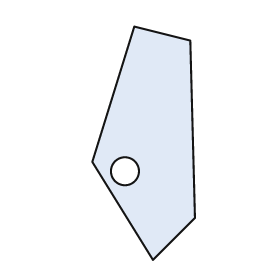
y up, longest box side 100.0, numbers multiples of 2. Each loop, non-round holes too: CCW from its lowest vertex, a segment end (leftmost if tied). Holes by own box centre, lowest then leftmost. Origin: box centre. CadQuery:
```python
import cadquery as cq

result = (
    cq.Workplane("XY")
    .moveTo(4.0, -50.0)
    .lineTo(22.0, -32.0)
    .lineTo(20.0, 44.0)
    .lineTo(-4.0, 50.0)
    .lineTo(-22.0, -8.0)
    .close()
    .moveTo(-8.0, -12.0)
    .circle(6.0)
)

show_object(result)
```